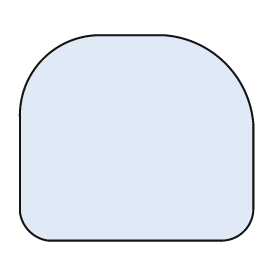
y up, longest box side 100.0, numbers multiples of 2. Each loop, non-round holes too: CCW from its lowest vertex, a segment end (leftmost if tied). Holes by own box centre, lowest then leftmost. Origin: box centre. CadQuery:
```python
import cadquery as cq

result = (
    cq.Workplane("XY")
    .moveTo(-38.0, -44.0)
    .lineTo(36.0, -44.0)
    .threePointArc((46.0, -40.0), (50.0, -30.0))
    .lineTo(50.0, 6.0)
    .threePointArc((38.0, 32.0), (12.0, 44.0))
    .lineTo(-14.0, 44.0)
    .threePointArc((-40.0, 34.0), (-50.0, 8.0))
    .lineTo(-50.0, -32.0)
    .threePointArc((-46.0, -40.0), (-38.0, -44.0))
    .close()
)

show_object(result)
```